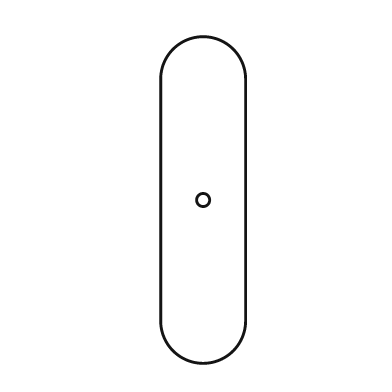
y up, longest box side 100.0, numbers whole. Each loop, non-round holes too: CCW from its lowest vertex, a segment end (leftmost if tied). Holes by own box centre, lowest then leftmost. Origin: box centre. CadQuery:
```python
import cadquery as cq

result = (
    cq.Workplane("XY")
    .moveTo(-13.0, -37.0)
    .threePointArc((0.0, -50.0), (13.0, -37.0))
    .lineTo(13.0, 37.0)
    .threePointArc((0.0, 50.0), (-13.0, 37.0))
    .close()
    .moveTo(0.0, 0.0)
    .circle(2.0)
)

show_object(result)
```